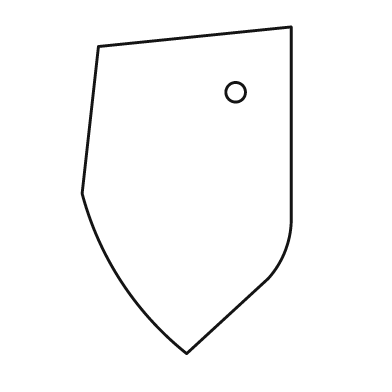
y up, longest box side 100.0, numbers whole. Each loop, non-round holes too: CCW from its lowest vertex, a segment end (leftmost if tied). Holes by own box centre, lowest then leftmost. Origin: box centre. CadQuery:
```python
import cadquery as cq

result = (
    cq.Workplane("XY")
    .moveTo(0.0, -50.0)
    .lineTo(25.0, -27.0)
    .threePointArc((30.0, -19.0), (32.0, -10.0))
    .lineTo(32.0, 50.0)
    .lineTo(-27.0, 44.0)
    .lineTo(-32.0, -1.0)
    .threePointArc((-20.0, -28.0), (0.0, -50.0))
    .close()
    .moveTo(15.0, 30.0)
    .circle(3.0)
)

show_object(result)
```